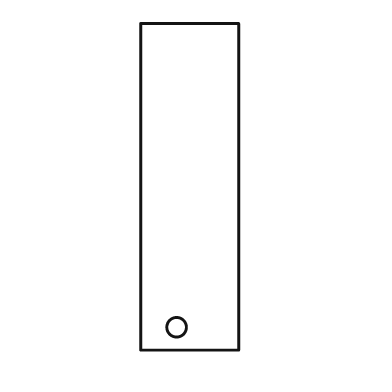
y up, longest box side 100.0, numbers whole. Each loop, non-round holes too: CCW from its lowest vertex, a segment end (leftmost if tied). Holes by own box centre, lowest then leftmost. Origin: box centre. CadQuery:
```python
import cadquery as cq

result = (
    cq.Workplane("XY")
    .moveTo(-15.0, -50.0)
    .lineTo(15.0, -50.0)
    .lineTo(15.0, 50.0)
    .lineTo(-15.0, 50.0)
    .close()
    .moveTo(-4.0, -43.0)
    .circle(3.0)
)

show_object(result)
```